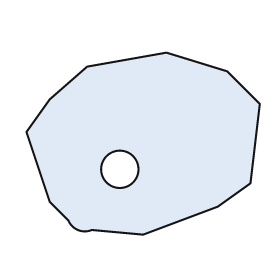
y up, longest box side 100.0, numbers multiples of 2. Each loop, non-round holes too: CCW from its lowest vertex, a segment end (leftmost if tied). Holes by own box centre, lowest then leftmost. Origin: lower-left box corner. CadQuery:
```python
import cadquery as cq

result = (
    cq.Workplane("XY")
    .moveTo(50.0, 0.0)
    .lineTo(82.0, 12.0)
    .lineTo(96.0, 22.0)
    .lineTo(100.0, 56.0)
    .lineTo(86.0, 70.0)
    .lineTo(60.0, 78.0)
    .lineTo(26.0, 72.0)
    .lineTo(10.0, 58.0)
    .lineTo(0.0, 44.0)
    .lineTo(10.0, 14.0)
    .lineTo(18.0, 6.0)
    .threePointArc((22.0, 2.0), (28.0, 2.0))
    .close()
    .moveTo(40.0, 28.0)
    .circle(8.0)
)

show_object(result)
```